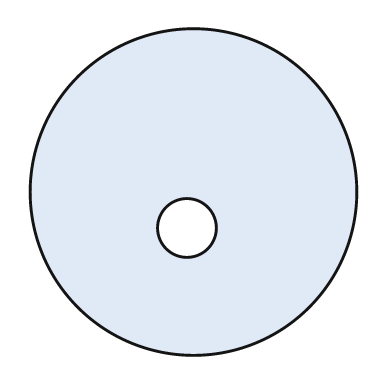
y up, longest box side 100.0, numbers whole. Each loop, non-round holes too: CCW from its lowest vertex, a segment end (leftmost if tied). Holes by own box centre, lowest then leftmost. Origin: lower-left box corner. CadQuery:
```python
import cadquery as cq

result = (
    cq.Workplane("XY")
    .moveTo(50.0, 50.0)
    .circle(50.0)
    .moveTo(48.0, 39.0)
    .circle(9.0)
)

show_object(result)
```